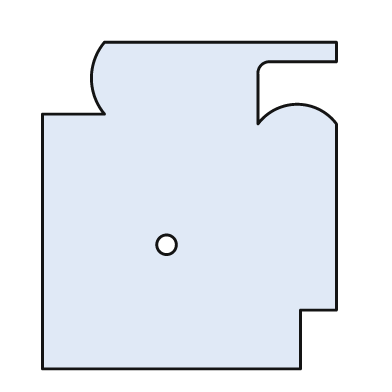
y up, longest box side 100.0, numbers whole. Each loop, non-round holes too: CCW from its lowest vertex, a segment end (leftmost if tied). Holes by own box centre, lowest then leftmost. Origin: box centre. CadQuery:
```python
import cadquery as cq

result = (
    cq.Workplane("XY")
    .moveTo(-45.0, -50.0)
    .lineTo(34.0, -50.0)
    .lineTo(34.0, -32.0)
    .lineTo(45.0, -32.0)
    .lineTo(45.0, 25.0)
    .threePointArc((33.0, 31.0), (21.0, 25.0))
    .lineTo(21.0, 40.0)
    .threePointArc((22.0, 43.0), (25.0, 44.0))
    .lineTo(45.0, 44.0)
    .lineTo(45.0, 50.0)
    .lineTo(-26.0, 50.0)
    .threePointArc((-30.0, 39.0), (-26.0, 28.0))
    .lineTo(-45.0, 28.0)
    .close()
    .moveTo(-7.0, -12.0)
    .circle(3.0)
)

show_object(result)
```